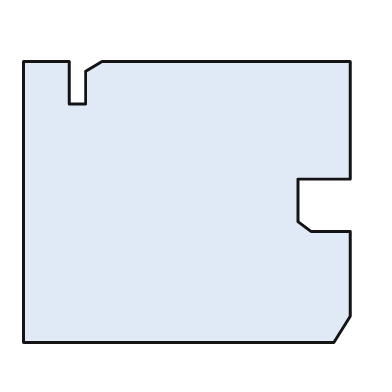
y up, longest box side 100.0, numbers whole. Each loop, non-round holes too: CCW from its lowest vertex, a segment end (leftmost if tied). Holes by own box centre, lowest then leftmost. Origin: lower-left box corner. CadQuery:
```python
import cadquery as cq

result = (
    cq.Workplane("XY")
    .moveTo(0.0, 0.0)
    .lineTo(95.0, 0.0)
    .lineTo(100.0, 8.0)
    .lineTo(100.0, 34.0)
    .lineTo(88.0, 34.0)
    .lineTo(84.0, 37.0)
    .lineTo(84.0, 50.0)
    .lineTo(100.0, 50.0)
    .lineTo(100.0, 86.0)
    .lineTo(24.0, 86.0)
    .lineTo(19.0, 83.0)
    .lineTo(19.0, 73.0)
    .lineTo(14.0, 73.0)
    .lineTo(14.0, 86.0)
    .lineTo(0.0, 86.0)
    .close()
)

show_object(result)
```